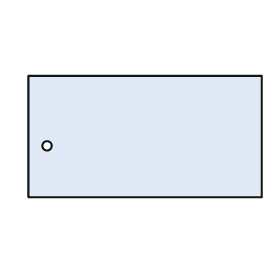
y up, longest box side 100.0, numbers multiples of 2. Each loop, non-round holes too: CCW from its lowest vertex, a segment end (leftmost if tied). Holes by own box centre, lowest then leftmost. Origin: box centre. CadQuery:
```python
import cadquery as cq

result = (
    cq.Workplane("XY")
    .moveTo(-50.0, -26.0)
    .lineTo(50.0, -26.0)
    .lineTo(50.0, 26.0)
    .lineTo(-50.0, 26.0)
    .close()
    .moveTo(-42.0, -4.0)
    .circle(2.0)
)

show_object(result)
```